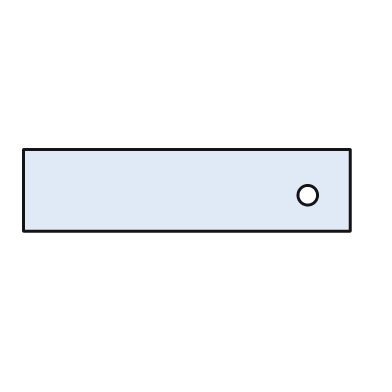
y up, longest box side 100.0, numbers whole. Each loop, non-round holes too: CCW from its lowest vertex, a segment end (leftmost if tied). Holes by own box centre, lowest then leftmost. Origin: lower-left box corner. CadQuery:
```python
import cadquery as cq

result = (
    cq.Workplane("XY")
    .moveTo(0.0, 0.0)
    .lineTo(100.0, 0.0)
    .lineTo(100.0, 25.0)
    .lineTo(0.0, 25.0)
    .close()
    .moveTo(87.0, 11.0)
    .circle(3.0)
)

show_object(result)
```